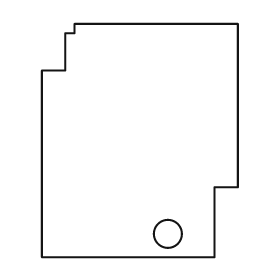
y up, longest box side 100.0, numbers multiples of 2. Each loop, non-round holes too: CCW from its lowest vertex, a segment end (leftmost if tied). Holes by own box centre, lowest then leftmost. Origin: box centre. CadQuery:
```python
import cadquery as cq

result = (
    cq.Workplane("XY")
    .moveTo(-42.0, -50.0)
    .lineTo(32.0, -50.0)
    .lineTo(32.0, -20.0)
    .lineTo(42.0, -20.0)
    .lineTo(42.0, 50.0)
    .lineTo(-28.0, 50.0)
    .lineTo(-28.0, 46.0)
    .lineTo(-32.0, 46.0)
    .lineTo(-32.0, 30.0)
    .lineTo(-42.0, 30.0)
    .close()
    .moveTo(12.0, -40.0)
    .circle(6.0)
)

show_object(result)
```